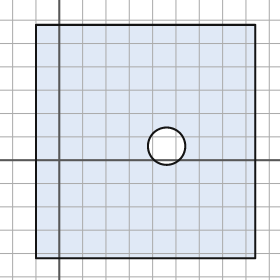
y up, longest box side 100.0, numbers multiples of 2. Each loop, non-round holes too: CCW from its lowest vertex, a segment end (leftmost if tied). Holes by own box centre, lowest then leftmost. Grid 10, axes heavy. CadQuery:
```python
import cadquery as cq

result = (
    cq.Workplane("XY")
    .moveTo(-10.0, -42.0)
    .lineTo(84.0, -42.0)
    .lineTo(84.0, 58.0)
    .lineTo(-10.0, 58.0)
    .close()
    .moveTo(46.0, 6.0)
    .circle(8.0)
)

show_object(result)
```